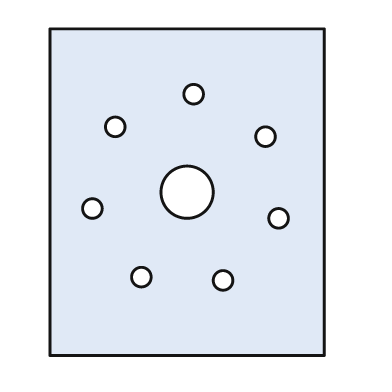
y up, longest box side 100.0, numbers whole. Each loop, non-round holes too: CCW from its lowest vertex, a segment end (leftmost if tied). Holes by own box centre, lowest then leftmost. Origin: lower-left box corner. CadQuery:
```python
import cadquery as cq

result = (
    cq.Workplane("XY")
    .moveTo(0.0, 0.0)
    .lineTo(84.0, 0.0)
    .lineTo(84.0, 100.0)
    .lineTo(0.0, 100.0)
    .close()
    .moveTo(53.0, 23.0)
    .circle(3.0)
    .moveTo(28.0, 24.0)
    .circle(3.0)
    .moveTo(70.0, 42.0)
    .circle(3.0)
    .moveTo(13.0, 45.0)
    .circle(3.0)
    .moveTo(42.0, 50.0)
    .circle(8.0)
    .moveTo(66.0, 67.0)
    .circle(3.0)
    .moveTo(20.0, 70.0)
    .circle(3.0)
    .moveTo(44.0, 80.0)
    .circle(3.0)
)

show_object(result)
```